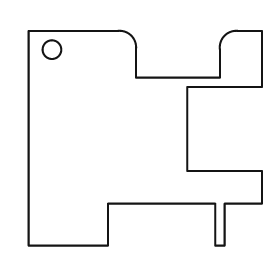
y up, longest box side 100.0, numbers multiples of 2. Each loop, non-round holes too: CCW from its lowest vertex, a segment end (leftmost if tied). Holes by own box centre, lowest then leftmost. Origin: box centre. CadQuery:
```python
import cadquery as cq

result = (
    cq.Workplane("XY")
    .moveTo(-50.0, -46.0)
    .lineTo(-16.0, -46.0)
    .lineTo(-16.0, -28.0)
    .lineTo(30.0, -28.0)
    .lineTo(30.0, -46.0)
    .lineTo(34.0, -46.0)
    .lineTo(34.0, -28.0)
    .lineTo(50.0, -28.0)
    .lineTo(50.0, -14.0)
    .lineTo(18.0, -14.0)
    .lineTo(18.0, 22.0)
    .lineTo(50.0, 22.0)
    .lineTo(50.0, 46.0)
    .lineTo(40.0, 46.0)
    .threePointArc((34.0, 44.0), (32.0, 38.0))
    .lineTo(32.0, 26.0)
    .lineTo(-4.0, 26.0)
    .lineTo(-4.0, 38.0)
    .threePointArc((-6.0, 44.0), (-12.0, 46.0))
    .lineTo(-50.0, 46.0)
    .close()
    .moveTo(-40.0, 38.0)
    .circle(4.0)
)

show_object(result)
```